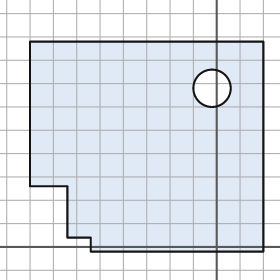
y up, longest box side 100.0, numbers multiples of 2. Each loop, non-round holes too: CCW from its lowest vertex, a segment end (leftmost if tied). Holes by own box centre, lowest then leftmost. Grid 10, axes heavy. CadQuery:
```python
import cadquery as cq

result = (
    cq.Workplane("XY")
    .moveTo(-54.0, -2.0)
    .lineTo(20.0, -2.0)
    .lineTo(20.0, 88.0)
    .lineTo(-80.0, 88.0)
    .lineTo(-80.0, 26.0)
    .lineTo(-64.0, 26.0)
    .lineTo(-64.0, 4.0)
    .lineTo(-54.0, 4.0)
    .close()
    .moveTo(-2.0, 68.0)
    .circle(8.0)
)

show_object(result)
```